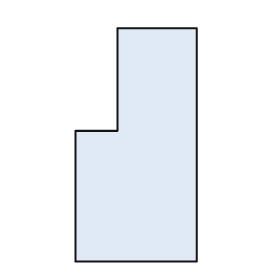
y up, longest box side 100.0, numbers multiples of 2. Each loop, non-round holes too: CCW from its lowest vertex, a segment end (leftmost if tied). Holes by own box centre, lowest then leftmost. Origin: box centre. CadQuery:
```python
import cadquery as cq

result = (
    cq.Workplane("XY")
    .moveTo(-26.0, -50.0)
    .lineTo(26.0, -50.0)
    .lineTo(26.0, 50.0)
    .lineTo(-8.0, 50.0)
    .lineTo(-8.0, 6.0)
    .lineTo(-26.0, 6.0)
    .close()
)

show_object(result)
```